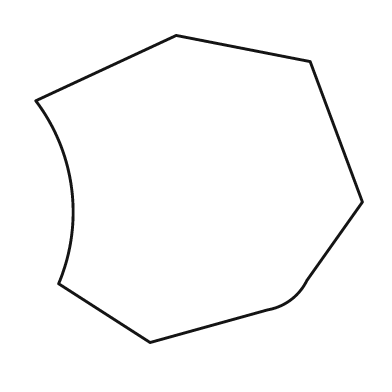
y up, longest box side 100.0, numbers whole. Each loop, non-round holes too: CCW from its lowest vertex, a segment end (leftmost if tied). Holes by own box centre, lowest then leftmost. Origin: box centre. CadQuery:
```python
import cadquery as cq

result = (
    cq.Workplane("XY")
    .moveTo(-15.0, -47.0)
    .lineTo(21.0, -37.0)
    .threePointArc((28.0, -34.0), (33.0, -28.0))
    .lineTo(50.0, -4.0)
    .lineTo(34.0, 39.0)
    .lineTo(-7.0, 47.0)
    .lineTo(-50.0, 27.0)
    .threePointArc((-39.0, 0.0), (-43.0, -29.0))
    .close()
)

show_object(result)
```